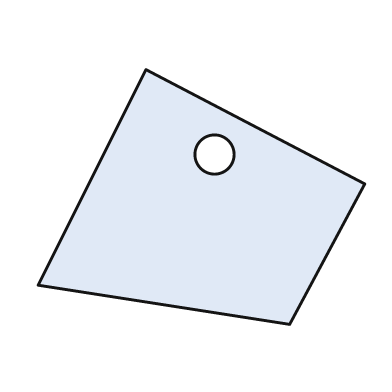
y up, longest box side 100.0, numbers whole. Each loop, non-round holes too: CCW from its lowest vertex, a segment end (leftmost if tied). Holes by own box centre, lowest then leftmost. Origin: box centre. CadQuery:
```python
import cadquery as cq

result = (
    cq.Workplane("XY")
    .moveTo(27.0, -39.0)
    .lineTo(50.0, 4.0)
    .lineTo(-17.0, 39.0)
    .lineTo(-50.0, -27.0)
    .close()
    .moveTo(4.0, 13.0)
    .circle(6.0)
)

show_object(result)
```